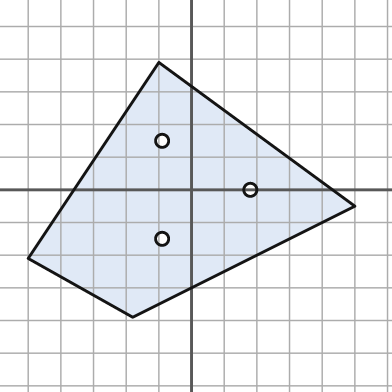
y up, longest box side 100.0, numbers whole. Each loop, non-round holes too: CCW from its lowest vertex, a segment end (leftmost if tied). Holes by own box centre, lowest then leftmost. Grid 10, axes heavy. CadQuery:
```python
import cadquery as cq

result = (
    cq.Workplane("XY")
    .moveTo(-18.0, -39.0)
    .lineTo(50.0, -5.0)
    .lineTo(-10.0, 39.0)
    .lineTo(-50.0, -21.0)
    .close()
    .moveTo(-9.0, -15.0)
    .circle(2.0)
    .moveTo(18.0, 0.0)
    .circle(2.0)
    .moveTo(-9.0, 15.0)
    .circle(2.0)
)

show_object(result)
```